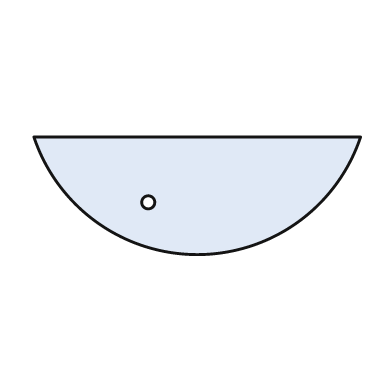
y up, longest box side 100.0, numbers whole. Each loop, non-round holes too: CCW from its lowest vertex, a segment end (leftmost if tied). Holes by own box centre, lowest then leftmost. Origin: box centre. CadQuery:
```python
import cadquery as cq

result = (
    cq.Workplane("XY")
    .moveTo(-50.0, 18.0)
    .threePointArc((0.0, -18.0), (50.0, 18.0))
    .close()
    .moveTo(-15.0, -2.0)
    .circle(2.0)
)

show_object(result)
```